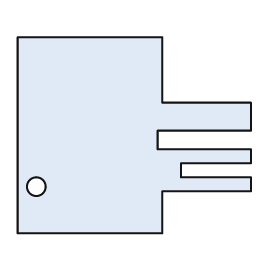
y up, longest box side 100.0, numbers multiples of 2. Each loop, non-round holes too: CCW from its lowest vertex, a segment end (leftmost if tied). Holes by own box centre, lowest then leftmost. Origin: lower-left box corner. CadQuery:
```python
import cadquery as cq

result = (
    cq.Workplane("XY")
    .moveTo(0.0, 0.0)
    .lineTo(62.0, 0.0)
    .lineTo(62.0, 18.0)
    .lineTo(100.0, 18.0)
    .lineTo(100.0, 24.0)
    .lineTo(70.0, 24.0)
    .lineTo(70.0, 30.0)
    .lineTo(100.0, 30.0)
    .lineTo(100.0, 36.0)
    .lineTo(60.0, 36.0)
    .lineTo(60.0, 44.0)
    .lineTo(100.0, 44.0)
    .lineTo(100.0, 56.0)
    .lineTo(62.0, 56.0)
    .lineTo(62.0, 84.0)
    .lineTo(0.0, 84.0)
    .close()
    .moveTo(8.0, 20.0)
    .circle(4.0)
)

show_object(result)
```